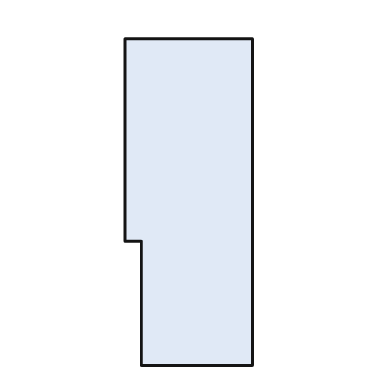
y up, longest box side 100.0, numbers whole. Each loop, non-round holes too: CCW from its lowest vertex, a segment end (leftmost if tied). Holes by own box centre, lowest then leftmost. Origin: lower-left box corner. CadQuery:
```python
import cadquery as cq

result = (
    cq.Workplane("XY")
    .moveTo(5.0, 0.0)
    .lineTo(39.0, 0.0)
    .lineTo(39.0, 100.0)
    .lineTo(0.0, 100.0)
    .lineTo(0.0, 38.0)
    .lineTo(5.0, 38.0)
    .close()
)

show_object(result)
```